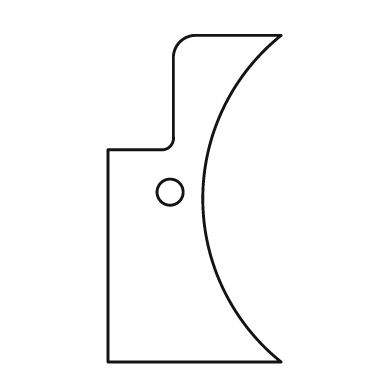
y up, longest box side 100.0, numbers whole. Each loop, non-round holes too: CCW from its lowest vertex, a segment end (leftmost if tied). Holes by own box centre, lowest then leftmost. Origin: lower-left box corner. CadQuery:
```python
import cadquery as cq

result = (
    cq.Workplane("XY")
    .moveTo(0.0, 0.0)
    .lineTo(53.0, 0.0)
    .threePointArc((29.0, 50.0), (53.0, 100.0))
    .lineTo(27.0, 100.0)
    .threePointArc((22.0, 98.0), (20.0, 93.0))
    .lineTo(20.0, 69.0)
    .threePointArc((19.0, 66.0), (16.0, 65.0))
    .lineTo(0.0, 65.0)
    .close()
    .moveTo(19.0, 52.0)
    .circle(4.0)
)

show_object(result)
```